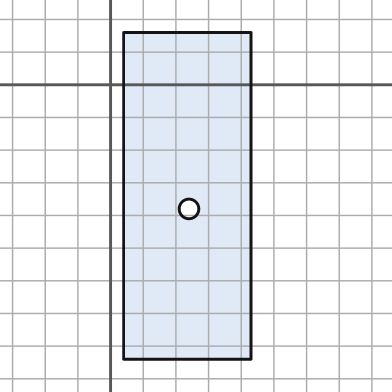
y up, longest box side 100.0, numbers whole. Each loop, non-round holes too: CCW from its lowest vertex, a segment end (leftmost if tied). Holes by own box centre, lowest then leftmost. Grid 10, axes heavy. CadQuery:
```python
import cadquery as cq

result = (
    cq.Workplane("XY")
    .moveTo(4.0, -84.0)
    .lineTo(43.0, -84.0)
    .lineTo(43.0, 16.0)
    .lineTo(4.0, 16.0)
    .close()
    .moveTo(24.0, -38.0)
    .circle(3.0)
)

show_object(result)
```